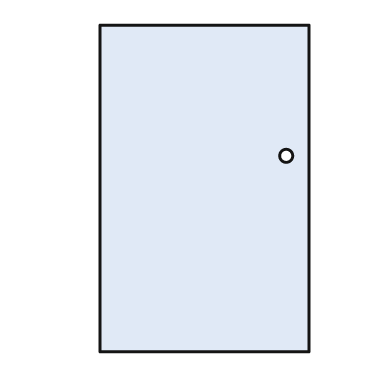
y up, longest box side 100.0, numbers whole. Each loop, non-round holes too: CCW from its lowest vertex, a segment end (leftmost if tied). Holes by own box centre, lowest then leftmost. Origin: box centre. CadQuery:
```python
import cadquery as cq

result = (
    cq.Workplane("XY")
    .moveTo(-32.0, -50.0)
    .lineTo(32.0, -50.0)
    .lineTo(32.0, 50.0)
    .lineTo(-32.0, 50.0)
    .close()
    .moveTo(25.0, 10.0)
    .circle(2.0)
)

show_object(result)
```